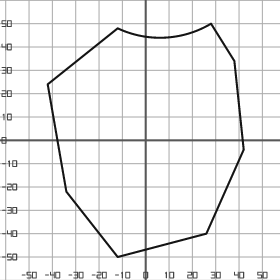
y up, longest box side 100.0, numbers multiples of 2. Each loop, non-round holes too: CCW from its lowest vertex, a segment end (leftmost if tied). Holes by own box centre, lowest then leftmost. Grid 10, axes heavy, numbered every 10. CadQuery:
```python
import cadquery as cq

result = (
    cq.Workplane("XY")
    .moveTo(-12.0, -50.0)
    .lineTo(26.0, -40.0)
    .lineTo(42.0, -4.0)
    .lineTo(38.0, 34.0)
    .lineTo(28.0, 50.0)
    .threePointArc((8.0, 44.0), (-12.0, 48.0))
    .lineTo(-42.0, 24.0)
    .lineTo(-34.0, -22.0)
    .close()
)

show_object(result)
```